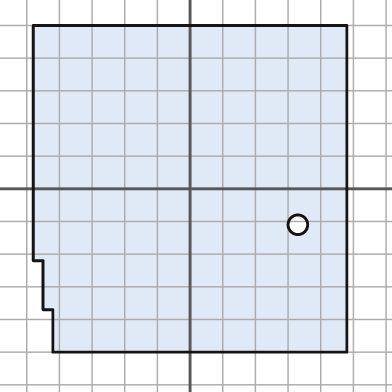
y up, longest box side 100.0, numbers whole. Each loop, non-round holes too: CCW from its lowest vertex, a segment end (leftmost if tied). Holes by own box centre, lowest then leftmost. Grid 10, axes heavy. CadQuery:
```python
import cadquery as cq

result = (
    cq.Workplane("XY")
    .moveTo(-42.0, -50.0)
    .lineTo(48.0, -50.0)
    .lineTo(48.0, 50.0)
    .lineTo(-48.0, 50.0)
    .lineTo(-48.0, -22.0)
    .lineTo(-45.0, -22.0)
    .lineTo(-45.0, -37.0)
    .lineTo(-42.0, -37.0)
    .close()
    .moveTo(33.0, -11.0)
    .circle(3.0)
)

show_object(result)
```